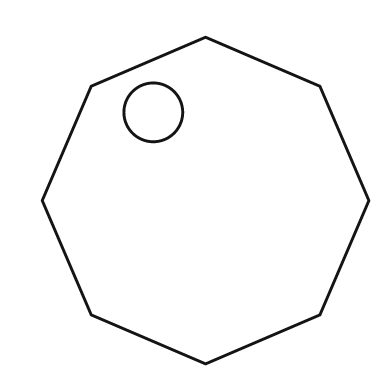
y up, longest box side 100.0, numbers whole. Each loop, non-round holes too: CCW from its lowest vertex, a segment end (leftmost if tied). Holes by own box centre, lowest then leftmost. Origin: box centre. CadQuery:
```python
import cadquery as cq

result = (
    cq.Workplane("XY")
    .moveTo(0.0, -50.0)
    .lineTo(35.0, -35.0)
    .lineTo(50.0, 0.0)
    .lineTo(35.0, 35.0)
    .lineTo(0.0, 50.0)
    .lineTo(-35.0, 35.0)
    .lineTo(-50.0, 0.0)
    .lineTo(-35.0, -35.0)
    .close()
    .moveTo(-16.0, 27.0)
    .circle(9.0)
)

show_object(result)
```